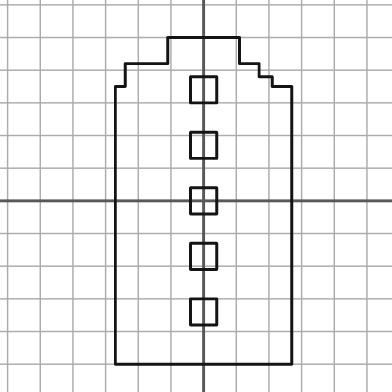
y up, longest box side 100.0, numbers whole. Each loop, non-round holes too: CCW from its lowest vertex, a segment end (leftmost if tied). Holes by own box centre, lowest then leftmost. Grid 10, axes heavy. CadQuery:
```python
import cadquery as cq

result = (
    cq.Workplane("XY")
    .moveTo(-27.0, -50.0)
    .lineTo(27.0, -50.0)
    .lineTo(27.0, 35.0)
    .lineTo(21.0, 35.0)
    .lineTo(21.0, 38.0)
    .lineTo(17.0, 38.0)
    .lineTo(17.0, 42.0)
    .lineTo(11.0, 42.0)
    .lineTo(11.0, 50.0)
    .lineTo(-11.0, 50.0)
    .lineTo(-11.0, 42.0)
    .lineTo(-24.0, 42.0)
    .lineTo(-24.0, 35.0)
    .lineTo(-27.0, 35.0)
    .close()
    .moveTo(-4.0, -38.0)
    .lineTo(4.0, -38.0)
    .lineTo(4.0, -30.0)
    .lineTo(-4.0, -30.0)
    .close()
    .moveTo(-4.0, -21.0)
    .lineTo(4.0, -21.0)
    .lineTo(4.0, -13.0)
    .lineTo(-4.0, -13.0)
    .close()
    .moveTo(-4.0, -4.0)
    .lineTo(4.0, -4.0)
    .lineTo(4.0, 4.0)
    .lineTo(-4.0, 4.0)
    .close()
    .moveTo(-4.0, 13.0)
    .lineTo(4.0, 13.0)
    .lineTo(4.0, 21.0)
    .lineTo(-4.0, 21.0)
    .close()
    .moveTo(-4.0, 30.0)
    .lineTo(4.0, 30.0)
    .lineTo(4.0, 38.0)
    .lineTo(-4.0, 38.0)
    .close()
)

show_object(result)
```